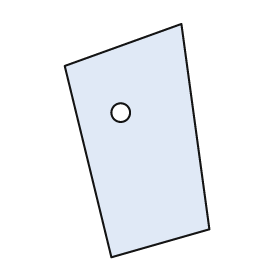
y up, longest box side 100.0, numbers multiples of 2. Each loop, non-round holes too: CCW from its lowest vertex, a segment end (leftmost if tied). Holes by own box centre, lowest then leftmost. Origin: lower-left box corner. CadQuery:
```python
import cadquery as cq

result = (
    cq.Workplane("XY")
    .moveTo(20.0, 0.0)
    .lineTo(62.0, 12.0)
    .lineTo(50.0, 100.0)
    .lineTo(0.0, 82.0)
    .close()
    .moveTo(24.0, 62.0)
    .circle(4.0)
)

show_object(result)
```